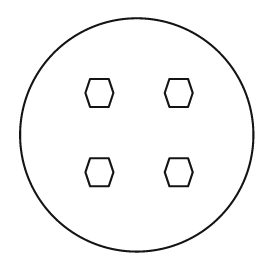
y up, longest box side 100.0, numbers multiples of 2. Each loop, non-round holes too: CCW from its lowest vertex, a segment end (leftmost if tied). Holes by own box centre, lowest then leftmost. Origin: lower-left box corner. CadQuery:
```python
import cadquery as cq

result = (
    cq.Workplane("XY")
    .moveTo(50.0, 50.0)
    .circle(50.0)
    .moveTo(30.0, 28.0)
    .lineTo(38.0, 28.0)
    .lineTo(40.0, 34.0)
    .lineTo(38.0, 40.0)
    .lineTo(30.0, 40.0)
    .lineTo(28.0, 34.0)
    .close()
    .moveTo(64.0, 28.0)
    .lineTo(72.0, 28.0)
    .lineTo(74.0, 34.0)
    .lineTo(72.0, 40.0)
    .lineTo(64.0, 40.0)
    .lineTo(62.0, 34.0)
    .close()
    .moveTo(30.0, 62.0)
    .lineTo(38.0, 62.0)
    .lineTo(40.0, 68.0)
    .lineTo(38.0, 74.0)
    .lineTo(30.0, 74.0)
    .lineTo(28.0, 68.0)
    .close()
    .moveTo(64.0, 62.0)
    .lineTo(72.0, 62.0)
    .lineTo(74.0, 68.0)
    .lineTo(72.0, 74.0)
    .lineTo(64.0, 74.0)
    .lineTo(62.0, 68.0)
    .close()
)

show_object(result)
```